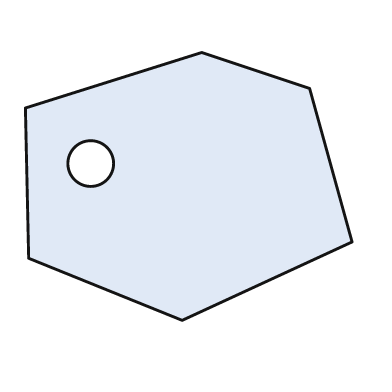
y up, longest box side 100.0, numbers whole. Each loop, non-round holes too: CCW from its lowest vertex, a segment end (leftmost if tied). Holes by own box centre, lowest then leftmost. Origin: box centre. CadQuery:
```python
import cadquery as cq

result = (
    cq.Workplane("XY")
    .moveTo(-2.0, -41.0)
    .lineTo(50.0, -17.0)
    .lineTo(37.0, 30.0)
    .lineTo(4.0, 41.0)
    .lineTo(-50.0, 24.0)
    .lineTo(-49.0, -22.0)
    .close()
    .moveTo(-30.0, 7.0)
    .circle(7.0)
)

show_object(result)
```